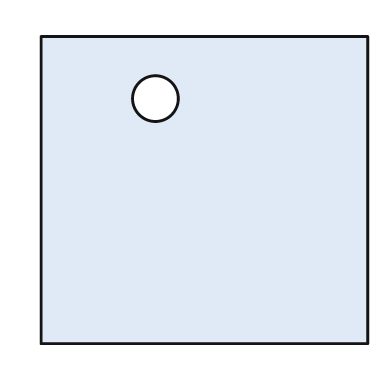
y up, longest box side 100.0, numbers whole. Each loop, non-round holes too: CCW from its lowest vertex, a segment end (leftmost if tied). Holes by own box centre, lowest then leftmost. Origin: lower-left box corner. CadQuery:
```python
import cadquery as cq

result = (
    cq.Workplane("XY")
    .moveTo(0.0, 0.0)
    .lineTo(100.0, 0.0)
    .lineTo(100.0, 94.0)
    .lineTo(0.0, 94.0)
    .close()
    .moveTo(35.0, 75.0)
    .circle(7.0)
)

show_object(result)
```